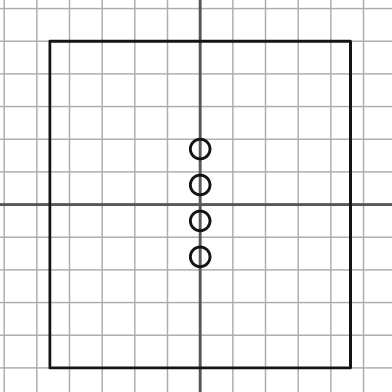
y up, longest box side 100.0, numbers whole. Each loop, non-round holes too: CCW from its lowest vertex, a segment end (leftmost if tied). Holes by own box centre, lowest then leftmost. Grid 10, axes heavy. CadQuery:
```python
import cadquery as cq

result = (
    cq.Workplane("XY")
    .moveTo(-46.0, -50.0)
    .lineTo(46.0, -50.0)
    .lineTo(46.0, 50.0)
    .lineTo(-46.0, 50.0)
    .close()
    .moveTo(0.0, -16.0)
    .circle(3.0)
    .moveTo(0.0, -5.0)
    .circle(3.0)
    .moveTo(0.0, 6.0)
    .circle(3.0)
    .moveTo(0.0, 17.0)
    .circle(3.0)
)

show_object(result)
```